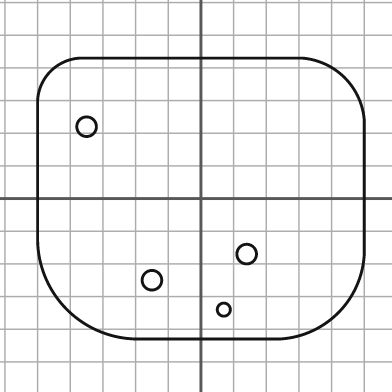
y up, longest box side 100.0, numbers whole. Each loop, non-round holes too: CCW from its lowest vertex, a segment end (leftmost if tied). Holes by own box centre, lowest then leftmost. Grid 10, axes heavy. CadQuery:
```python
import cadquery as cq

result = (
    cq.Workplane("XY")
    .moveTo(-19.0, -43.0)
    .lineTo(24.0, -43.0)
    .threePointArc((42.0, -35.0), (50.0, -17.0))
    .lineTo(50.0, 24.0)
    .threePointArc((44.0, 37.0), (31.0, 43.0))
    .lineTo(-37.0, 43.0)
    .threePointArc((-46.0, 39.0), (-50.0, 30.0))
    .lineTo(-50.0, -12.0)
    .threePointArc((-41.0, -34.0), (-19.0, -43.0))
    .close()
    .moveTo(7.0, -34.0)
    .circle(2.0)
    .moveTo(-15.0, -25.0)
    .circle(3.0)
    .moveTo(14.0, -17.0)
    .circle(3.0)
    .moveTo(-35.0, 22.0)
    .circle(3.0)
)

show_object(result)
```